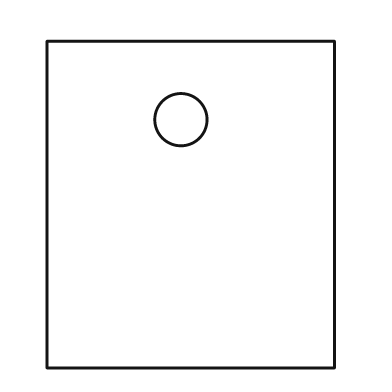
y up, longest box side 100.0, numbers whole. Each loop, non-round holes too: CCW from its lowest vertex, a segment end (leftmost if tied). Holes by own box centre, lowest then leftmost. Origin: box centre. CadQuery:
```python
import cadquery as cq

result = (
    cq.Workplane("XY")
    .moveTo(-44.0, -50.0)
    .lineTo(44.0, -50.0)
    .lineTo(44.0, 50.0)
    .lineTo(-44.0, 50.0)
    .close()
    .moveTo(-3.0, 26.0)
    .circle(8.0)
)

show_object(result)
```